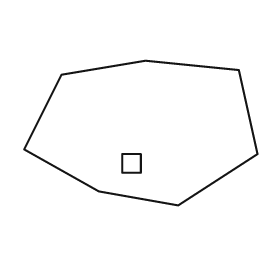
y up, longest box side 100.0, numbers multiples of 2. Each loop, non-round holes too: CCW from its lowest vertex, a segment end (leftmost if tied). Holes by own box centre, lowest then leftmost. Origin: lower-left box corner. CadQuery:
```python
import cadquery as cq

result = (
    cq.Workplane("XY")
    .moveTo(66.0, 0.0)
    .lineTo(100.0, 22.0)
    .lineTo(92.0, 58.0)
    .lineTo(52.0, 62.0)
    .lineTo(16.0, 56.0)
    .lineTo(0.0, 24.0)
    .lineTo(32.0, 6.0)
    .close()
    .moveTo(42.0, 14.0)
    .lineTo(50.0, 14.0)
    .lineTo(50.0, 22.0)
    .lineTo(42.0, 22.0)
    .close()
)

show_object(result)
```